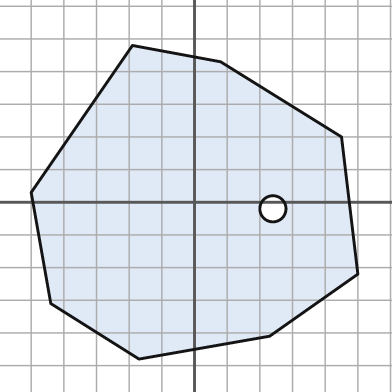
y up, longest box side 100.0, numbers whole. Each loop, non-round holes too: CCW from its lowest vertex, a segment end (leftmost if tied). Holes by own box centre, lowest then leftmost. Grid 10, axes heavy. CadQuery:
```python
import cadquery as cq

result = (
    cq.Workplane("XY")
    .moveTo(-17.0, -48.0)
    .lineTo(23.0, -41.0)
    .lineTo(50.0, -22.0)
    .lineTo(45.0, 20.0)
    .lineTo(8.0, 43.0)
    .lineTo(-19.0, 48.0)
    .lineTo(-50.0, 3.0)
    .lineTo(-44.0, -31.0)
    .close()
    .moveTo(24.0, -2.0)
    .circle(4.0)
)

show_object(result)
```